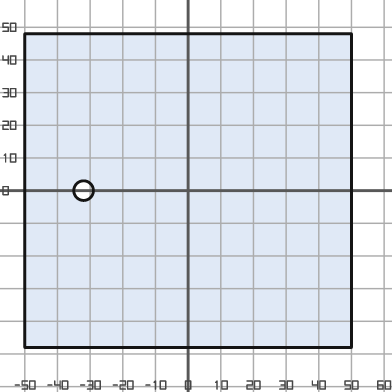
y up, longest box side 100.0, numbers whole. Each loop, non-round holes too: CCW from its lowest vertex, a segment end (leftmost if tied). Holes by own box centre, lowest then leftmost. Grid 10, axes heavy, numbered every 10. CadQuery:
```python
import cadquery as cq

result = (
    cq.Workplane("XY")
    .moveTo(-50.0, -48.0)
    .lineTo(50.0, -48.0)
    .lineTo(50.0, 48.0)
    .lineTo(-50.0, 48.0)
    .close()
    .moveTo(-32.0, 0.0)
    .circle(3.0)
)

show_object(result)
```